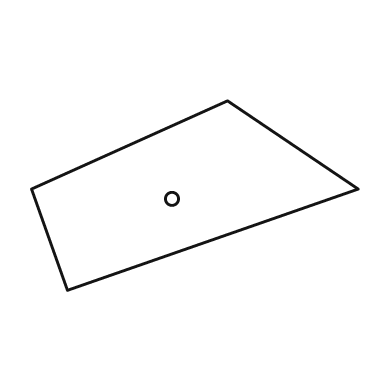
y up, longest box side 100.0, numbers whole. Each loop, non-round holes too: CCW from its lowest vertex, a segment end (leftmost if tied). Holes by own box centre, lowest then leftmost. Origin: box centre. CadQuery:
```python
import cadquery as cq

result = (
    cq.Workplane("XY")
    .moveTo(-39.0, -29.0)
    .lineTo(50.0, 2.0)
    .lineTo(10.0, 29.0)
    .lineTo(-50.0, 2.0)
    .close()
    .moveTo(-7.0, -1.0)
    .circle(2.0)
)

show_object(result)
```